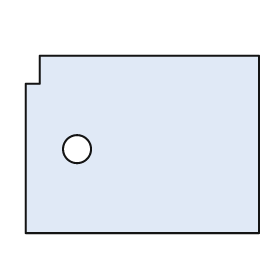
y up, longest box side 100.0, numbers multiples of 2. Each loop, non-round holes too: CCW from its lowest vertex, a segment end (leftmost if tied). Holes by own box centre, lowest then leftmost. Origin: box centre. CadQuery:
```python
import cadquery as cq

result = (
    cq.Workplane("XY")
    .moveTo(-50.0, -38.0)
    .lineTo(50.0, -38.0)
    .lineTo(50.0, 38.0)
    .lineTo(-44.0, 38.0)
    .lineTo(-44.0, 26.0)
    .lineTo(-50.0, 26.0)
    .close()
    .moveTo(-28.0, -2.0)
    .circle(6.0)
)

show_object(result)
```